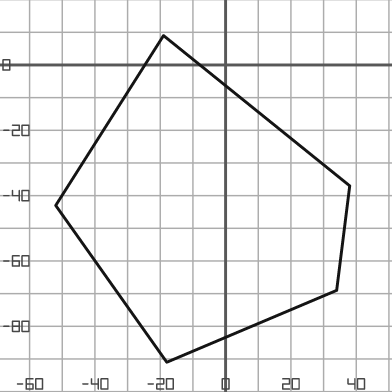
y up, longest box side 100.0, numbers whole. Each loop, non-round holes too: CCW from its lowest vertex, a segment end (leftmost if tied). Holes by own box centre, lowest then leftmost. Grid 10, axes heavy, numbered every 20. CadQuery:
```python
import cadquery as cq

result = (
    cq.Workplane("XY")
    .moveTo(-18.0, -91.0)
    .lineTo(34.0, -69.0)
    .lineTo(38.0, -37.0)
    .lineTo(-19.0, 9.0)
    .lineTo(-52.0, -43.0)
    .close()
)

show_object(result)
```